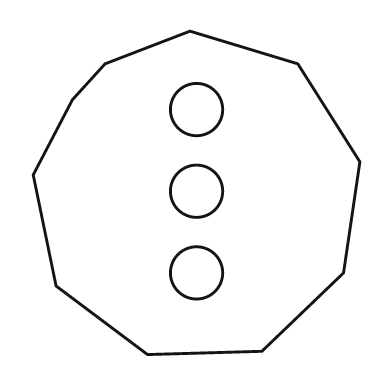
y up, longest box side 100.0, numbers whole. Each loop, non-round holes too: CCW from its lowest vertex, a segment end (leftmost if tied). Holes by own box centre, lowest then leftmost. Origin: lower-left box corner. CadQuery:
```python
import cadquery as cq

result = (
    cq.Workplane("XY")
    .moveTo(35.0, 0.0)
    .lineTo(70.0, 1.0)
    .lineTo(95.0, 25.0)
    .lineTo(100.0, 59.0)
    .lineTo(81.0, 89.0)
    .lineTo(48.0, 99.0)
    .lineTo(22.0, 89.0)
    .lineTo(12.0, 78.0)
    .lineTo(0.0, 55.0)
    .lineTo(7.0, 21.0)
    .close()
    .moveTo(50.0, 25.0)
    .circle(8.0)
    .moveTo(50.0, 50.0)
    .circle(8.0)
    .moveTo(50.0, 75.0)
    .circle(8.0)
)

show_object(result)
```